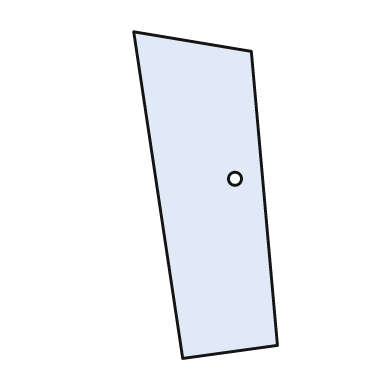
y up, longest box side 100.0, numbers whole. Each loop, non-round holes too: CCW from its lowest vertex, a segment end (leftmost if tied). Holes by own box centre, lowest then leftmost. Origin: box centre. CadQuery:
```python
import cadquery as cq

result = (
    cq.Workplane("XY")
    .moveTo(-7.0, -50.0)
    .lineTo(22.0, -46.0)
    .lineTo(14.0, 44.0)
    .lineTo(-22.0, 50.0)
    .close()
    .moveTo(9.0, 5.0)
    .circle(2.0)
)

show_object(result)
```